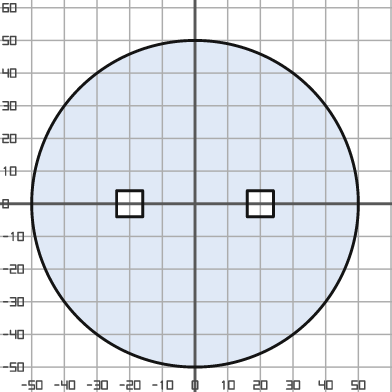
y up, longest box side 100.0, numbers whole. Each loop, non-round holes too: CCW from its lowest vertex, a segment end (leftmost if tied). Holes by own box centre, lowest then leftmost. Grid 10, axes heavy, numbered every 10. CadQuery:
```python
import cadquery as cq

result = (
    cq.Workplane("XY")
    .moveTo(0.0, 0.0)
    .circle(50.0)
    .moveTo(-24.0, -4.0)
    .lineTo(-16.0, -4.0)
    .lineTo(-16.0, 4.0)
    .lineTo(-24.0, 4.0)
    .close()
    .moveTo(16.0, -4.0)
    .lineTo(24.0, -4.0)
    .lineTo(24.0, 4.0)
    .lineTo(16.0, 4.0)
    .close()
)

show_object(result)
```